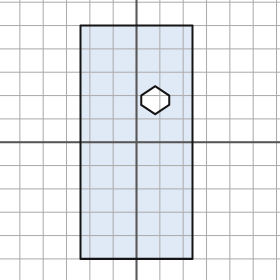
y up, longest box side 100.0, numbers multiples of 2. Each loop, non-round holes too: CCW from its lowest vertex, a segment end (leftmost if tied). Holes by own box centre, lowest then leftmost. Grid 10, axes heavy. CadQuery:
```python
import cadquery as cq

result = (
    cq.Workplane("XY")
    .moveTo(-24.0, -50.0)
    .lineTo(24.0, -50.0)
    .lineTo(24.0, 50.0)
    .lineTo(-24.0, 50.0)
    .close()
    .moveTo(8.0, 12.0)
    .lineTo(14.0, 16.0)
    .lineTo(14.0, 20.0)
    .lineTo(8.0, 24.0)
    .lineTo(2.0, 20.0)
    .lineTo(2.0, 16.0)
    .close()
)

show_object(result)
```